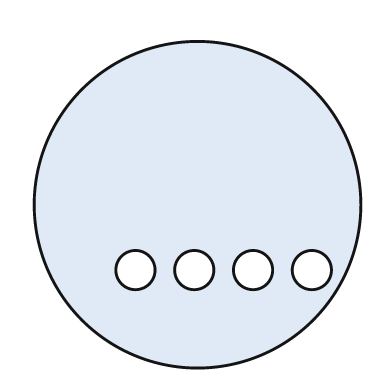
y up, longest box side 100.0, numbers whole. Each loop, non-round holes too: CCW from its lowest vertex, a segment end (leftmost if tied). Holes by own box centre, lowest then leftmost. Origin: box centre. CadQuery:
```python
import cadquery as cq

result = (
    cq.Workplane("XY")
    .moveTo(0.0, 0.0)
    .circle(50.0)
    .moveTo(-19.0, -20.0)
    .circle(6.0)
    .moveTo(-1.0, -20.0)
    .circle(6.0)
    .moveTo(17.0, -20.0)
    .circle(6.0)
    .moveTo(35.0, -20.0)
    .circle(6.0)
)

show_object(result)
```